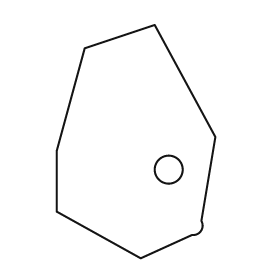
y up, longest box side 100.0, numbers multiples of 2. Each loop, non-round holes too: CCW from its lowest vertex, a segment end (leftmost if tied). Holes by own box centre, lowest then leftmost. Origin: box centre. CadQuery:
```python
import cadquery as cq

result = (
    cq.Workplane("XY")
    .moveTo(2.0, -50.0)
    .lineTo(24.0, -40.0)
    .threePointArc((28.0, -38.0), (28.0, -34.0))
    .lineTo(34.0, 2.0)
    .lineTo(8.0, 50.0)
    .lineTo(-22.0, 40.0)
    .lineTo(-34.0, -4.0)
    .lineTo(-34.0, -30.0)
    .close()
    .moveTo(14.0, -12.0)
    .circle(6.0)
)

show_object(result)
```